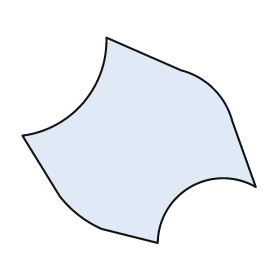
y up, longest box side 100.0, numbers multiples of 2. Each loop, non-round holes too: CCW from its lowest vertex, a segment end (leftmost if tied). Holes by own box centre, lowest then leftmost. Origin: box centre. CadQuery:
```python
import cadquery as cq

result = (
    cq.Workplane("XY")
    .moveTo(8.0, -44.0)
    .threePointArc((22.0, -20.0), (50.0, -20.0))
    .lineTo(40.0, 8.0)
    .threePointArc((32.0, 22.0), (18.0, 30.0))
    .lineTo(-14.0, 44.0)
    .threePointArc((-24.0, 16.0), (-50.0, 2.0))
    .lineTo(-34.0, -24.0)
    .threePointArc((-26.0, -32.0), (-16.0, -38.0))
    .close()
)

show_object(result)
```